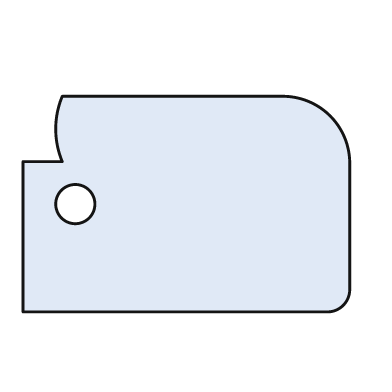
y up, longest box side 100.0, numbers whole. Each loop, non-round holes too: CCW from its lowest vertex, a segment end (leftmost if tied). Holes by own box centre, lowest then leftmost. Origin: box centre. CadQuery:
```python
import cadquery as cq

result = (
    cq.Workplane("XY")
    .moveTo(-50.0, -33.0)
    .lineTo(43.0, -33.0)
    .threePointArc((48.0, -31.0), (50.0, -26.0))
    .lineTo(50.0, 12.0)
    .threePointArc((44.0, 27.0), (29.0, 33.0))
    .lineTo(-38.0, 33.0)
    .threePointArc((-40.0, 23.0), (-38.0, 13.0))
    .lineTo(-50.0, 13.0)
    .close()
    .moveTo(-34.0, 0.0)
    .circle(6.0)
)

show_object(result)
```